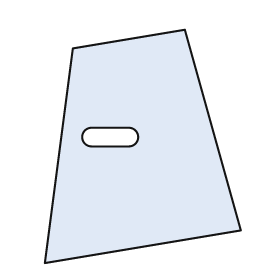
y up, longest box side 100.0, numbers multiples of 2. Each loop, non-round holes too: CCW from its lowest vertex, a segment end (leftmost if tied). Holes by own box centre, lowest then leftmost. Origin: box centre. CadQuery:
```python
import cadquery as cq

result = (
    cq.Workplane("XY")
    .moveTo(-42.0, -50.0)
    .lineTo(42.0, -36.0)
    .lineTo(18.0, 50.0)
    .lineTo(-30.0, 42.0)
    .close()
    .moveTo(-22.0, 0.0)
    .lineTo(-6.0, 0.0)
    .threePointArc((-2.0, 4.0), (-6.0, 8.0))
    .lineTo(-22.0, 8.0)
    .threePointArc((-26.0, 4.0), (-22.0, 0.0))
    .close()
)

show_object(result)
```